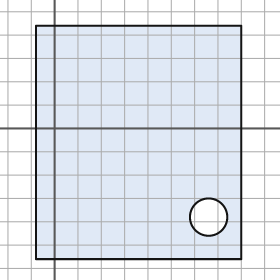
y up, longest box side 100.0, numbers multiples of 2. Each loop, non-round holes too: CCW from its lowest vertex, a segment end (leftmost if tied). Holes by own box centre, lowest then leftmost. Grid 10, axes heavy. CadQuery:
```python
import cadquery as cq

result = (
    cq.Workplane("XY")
    .moveTo(-8.0, -56.0)
    .lineTo(80.0, -56.0)
    .lineTo(80.0, 44.0)
    .lineTo(-8.0, 44.0)
    .close()
    .moveTo(66.0, -38.0)
    .circle(8.0)
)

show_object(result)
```